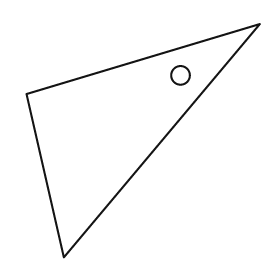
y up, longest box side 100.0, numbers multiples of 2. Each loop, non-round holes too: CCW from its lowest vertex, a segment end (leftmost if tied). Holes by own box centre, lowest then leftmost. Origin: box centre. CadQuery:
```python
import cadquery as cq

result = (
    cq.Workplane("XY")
    .moveTo(-34.0, -50.0)
    .lineTo(50.0, 50.0)
    .lineTo(-50.0, 20.0)
    .close()
    .moveTo(16.0, 28.0)
    .circle(4.0)
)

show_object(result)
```